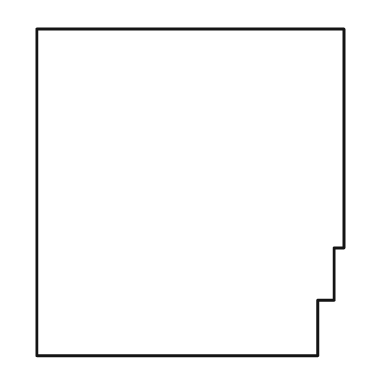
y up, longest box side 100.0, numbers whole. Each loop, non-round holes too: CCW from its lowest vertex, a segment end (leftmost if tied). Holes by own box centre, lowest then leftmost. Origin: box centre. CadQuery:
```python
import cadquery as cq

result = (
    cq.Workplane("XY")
    .moveTo(-47.0, -50.0)
    .lineTo(39.0, -50.0)
    .lineTo(39.0, -33.0)
    .lineTo(44.0, -33.0)
    .lineTo(44.0, -17.0)
    .lineTo(47.0, -17.0)
    .lineTo(47.0, 50.0)
    .lineTo(-47.0, 50.0)
    .close()
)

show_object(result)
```